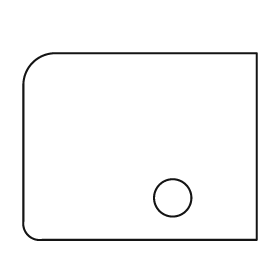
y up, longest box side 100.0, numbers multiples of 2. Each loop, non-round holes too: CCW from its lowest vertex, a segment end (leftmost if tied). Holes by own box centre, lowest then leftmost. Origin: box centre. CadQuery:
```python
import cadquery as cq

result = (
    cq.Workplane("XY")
    .moveTo(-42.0, -40.0)
    .lineTo(50.0, -40.0)
    .lineTo(50.0, 40.0)
    .lineTo(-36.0, 40.0)
    .threePointArc((-46.0, 36.0), (-50.0, 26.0))
    .lineTo(-50.0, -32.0)
    .threePointArc((-48.0, -38.0), (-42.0, -40.0))
    .close()
    .moveTo(14.0, -22.0)
    .circle(8.0)
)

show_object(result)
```